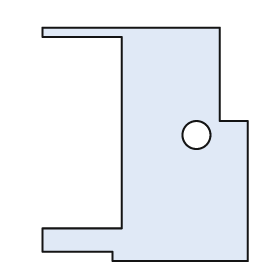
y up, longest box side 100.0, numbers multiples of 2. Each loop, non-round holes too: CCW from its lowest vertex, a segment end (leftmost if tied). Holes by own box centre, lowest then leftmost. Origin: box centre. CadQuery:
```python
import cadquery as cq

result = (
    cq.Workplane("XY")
    .moveTo(-14.0, -50.0)
    .lineTo(44.0, -50.0)
    .lineTo(44.0, 10.0)
    .lineTo(32.0, 10.0)
    .lineTo(32.0, 50.0)
    .lineTo(-44.0, 50.0)
    .lineTo(-44.0, 46.0)
    .lineTo(-10.0, 46.0)
    .lineTo(-10.0, -36.0)
    .lineTo(-44.0, -36.0)
    .lineTo(-44.0, -46.0)
    .lineTo(-14.0, -46.0)
    .close()
    .moveTo(22.0, 4.0)
    .circle(6.0)
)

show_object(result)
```